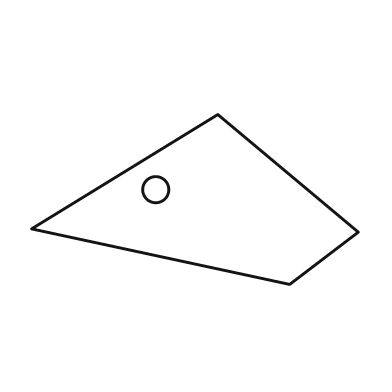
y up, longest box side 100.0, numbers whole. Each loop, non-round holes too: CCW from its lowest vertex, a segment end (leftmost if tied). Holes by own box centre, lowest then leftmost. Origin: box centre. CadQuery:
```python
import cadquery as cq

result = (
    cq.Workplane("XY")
    .moveTo(29.0, -26.0)
    .lineTo(50.0, -10.0)
    .lineTo(7.0, 26.0)
    .lineTo(-50.0, -9.0)
    .close()
    .moveTo(-12.0, 3.0)
    .circle(4.0)
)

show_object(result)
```